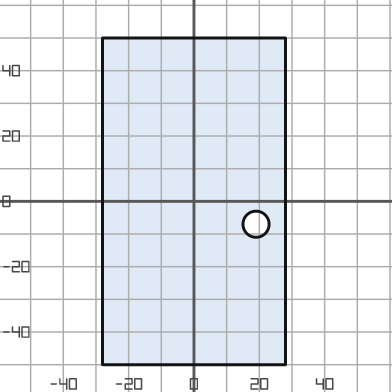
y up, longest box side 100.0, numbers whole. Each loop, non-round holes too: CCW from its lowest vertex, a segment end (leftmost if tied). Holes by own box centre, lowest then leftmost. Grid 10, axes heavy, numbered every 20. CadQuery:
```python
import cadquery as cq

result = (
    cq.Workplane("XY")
    .moveTo(-28.0, -50.0)
    .lineTo(28.0, -50.0)
    .lineTo(28.0, 50.0)
    .lineTo(-28.0, 50.0)
    .close()
    .moveTo(19.0, -7.0)
    .circle(4.0)
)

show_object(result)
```